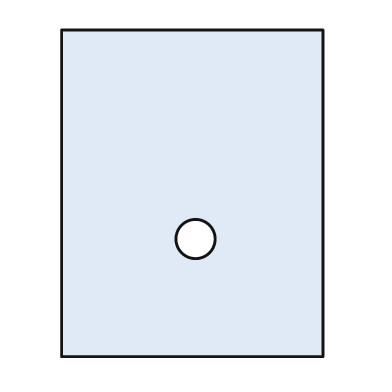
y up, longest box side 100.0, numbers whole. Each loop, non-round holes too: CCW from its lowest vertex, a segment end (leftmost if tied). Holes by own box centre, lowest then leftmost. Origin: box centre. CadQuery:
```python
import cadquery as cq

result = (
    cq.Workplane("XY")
    .moveTo(-40.0, -50.0)
    .lineTo(40.0, -50.0)
    .lineTo(40.0, 50.0)
    .lineTo(-40.0, 50.0)
    .close()
    .moveTo(1.0, -14.0)
    .circle(6.0)
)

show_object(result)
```